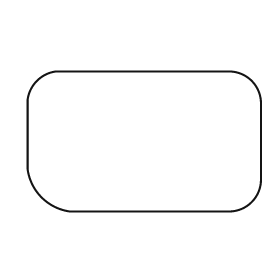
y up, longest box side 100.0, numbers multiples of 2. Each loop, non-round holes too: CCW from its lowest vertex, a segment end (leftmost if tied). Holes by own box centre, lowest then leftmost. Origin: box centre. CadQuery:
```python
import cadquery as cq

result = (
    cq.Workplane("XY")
    .moveTo(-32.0, -30.0)
    .lineTo(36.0, -30.0)
    .threePointArc((46.0, -26.0), (50.0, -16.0))
    .lineTo(50.0, 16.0)
    .threePointArc((46.0, 26.0), (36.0, 30.0))
    .lineTo(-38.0, 30.0)
    .threePointArc((-46.0, 26.0), (-50.0, 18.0))
    .lineTo(-50.0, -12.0)
    .threePointArc((-44.0, -24.0), (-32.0, -30.0))
    .close()
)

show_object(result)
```